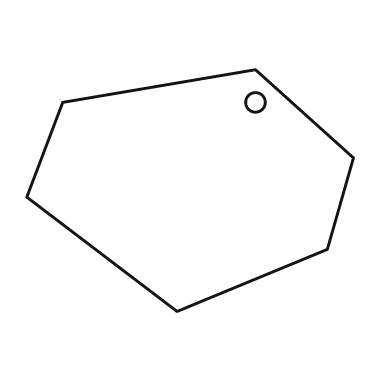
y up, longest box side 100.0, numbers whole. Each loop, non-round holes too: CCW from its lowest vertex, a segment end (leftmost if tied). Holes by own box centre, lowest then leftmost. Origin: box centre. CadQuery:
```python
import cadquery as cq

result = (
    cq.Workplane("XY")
    .moveTo(-4.0, -37.0)
    .lineTo(42.0, -18.0)
    .lineTo(50.0, 10.0)
    .lineTo(20.0, 37.0)
    .lineTo(-39.0, 27.0)
    .lineTo(-50.0, -2.0)
    .close()
    .moveTo(20.0, 27.0)
    .circle(3.0)
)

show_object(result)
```